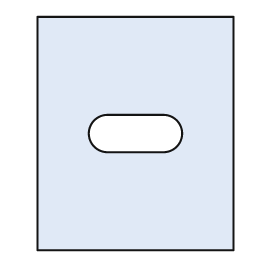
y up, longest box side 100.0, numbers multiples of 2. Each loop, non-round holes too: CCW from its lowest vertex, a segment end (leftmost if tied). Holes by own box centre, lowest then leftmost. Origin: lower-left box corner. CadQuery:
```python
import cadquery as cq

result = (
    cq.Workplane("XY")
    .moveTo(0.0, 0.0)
    .lineTo(84.0, 0.0)
    .lineTo(84.0, 100.0)
    .lineTo(0.0, 100.0)
    .close()
    .moveTo(30.0, 42.0)
    .lineTo(54.0, 42.0)
    .threePointArc((62.0, 50.0), (54.0, 58.0))
    .lineTo(30.0, 58.0)
    .threePointArc((22.0, 50.0), (30.0, 42.0))
    .close()
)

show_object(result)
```